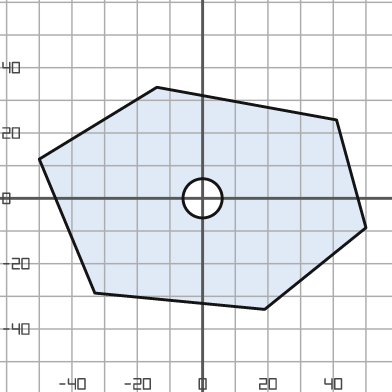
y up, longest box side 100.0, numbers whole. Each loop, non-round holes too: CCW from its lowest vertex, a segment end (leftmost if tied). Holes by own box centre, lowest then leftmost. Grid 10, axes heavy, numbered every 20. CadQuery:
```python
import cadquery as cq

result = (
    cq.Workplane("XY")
    .moveTo(19.0, -34.0)
    .lineTo(50.0, -9.0)
    .lineTo(41.0, 24.0)
    .lineTo(-14.0, 34.0)
    .lineTo(-50.0, 12.0)
    .lineTo(-33.0, -29.0)
    .close()
    .moveTo(0.0, 0.0)
    .circle(6.0)
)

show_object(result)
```